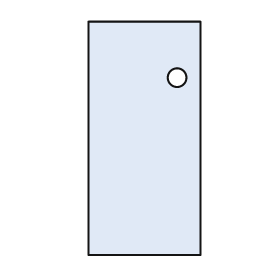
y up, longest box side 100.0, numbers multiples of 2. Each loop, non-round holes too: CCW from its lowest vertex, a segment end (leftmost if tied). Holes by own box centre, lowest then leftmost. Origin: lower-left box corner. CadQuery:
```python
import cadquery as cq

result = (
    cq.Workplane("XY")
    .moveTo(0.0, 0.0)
    .lineTo(48.0, 0.0)
    .lineTo(48.0, 100.0)
    .lineTo(0.0, 100.0)
    .close()
    .moveTo(38.0, 76.0)
    .circle(4.0)
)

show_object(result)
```